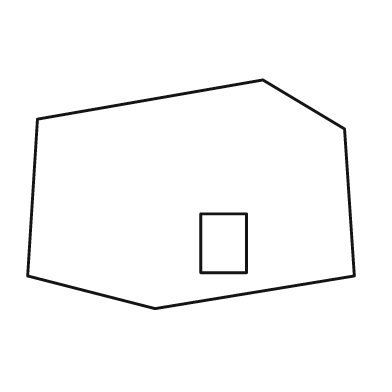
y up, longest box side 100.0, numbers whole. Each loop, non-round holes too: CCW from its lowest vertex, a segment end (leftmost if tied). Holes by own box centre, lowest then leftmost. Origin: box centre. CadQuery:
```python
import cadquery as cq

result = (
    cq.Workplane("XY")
    .moveTo(-11.0, -35.0)
    .lineTo(50.0, -25.0)
    .lineTo(47.0, 20.0)
    .lineTo(22.0, 35.0)
    .lineTo(-47.0, 23.0)
    .lineTo(-50.0, -25.0)
    .close()
    .moveTo(3.0, -24.0)
    .lineTo(17.0, -24.0)
    .lineTo(17.0, -6.0)
    .lineTo(3.0, -6.0)
    .close()
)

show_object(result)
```